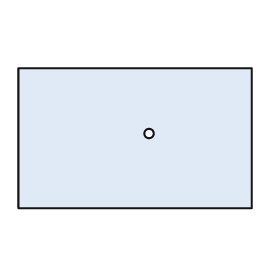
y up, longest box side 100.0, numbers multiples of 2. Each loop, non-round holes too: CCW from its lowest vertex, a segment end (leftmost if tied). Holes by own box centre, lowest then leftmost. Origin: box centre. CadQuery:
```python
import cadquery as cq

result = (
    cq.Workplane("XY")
    .moveTo(-50.0, -30.0)
    .lineTo(50.0, -30.0)
    .lineTo(50.0, 30.0)
    .lineTo(-50.0, 30.0)
    .close()
    .moveTo(6.0, 2.0)
    .circle(2.0)
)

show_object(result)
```